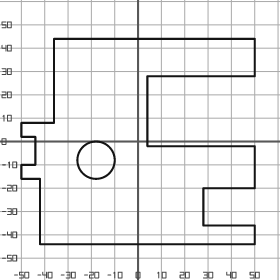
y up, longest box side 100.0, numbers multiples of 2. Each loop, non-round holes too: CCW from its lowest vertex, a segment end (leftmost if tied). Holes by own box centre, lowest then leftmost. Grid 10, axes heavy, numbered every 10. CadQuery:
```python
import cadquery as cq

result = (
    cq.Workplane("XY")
    .moveTo(-42.0, -44.0)
    .lineTo(50.0, -44.0)
    .lineTo(50.0, -36.0)
    .lineTo(28.0, -36.0)
    .lineTo(28.0, -20.0)
    .lineTo(50.0, -20.0)
    .lineTo(50.0, -2.0)
    .lineTo(4.0, -2.0)
    .lineTo(4.0, 28.0)
    .lineTo(50.0, 28.0)
    .lineTo(50.0, 44.0)
    .lineTo(-36.0, 44.0)
    .lineTo(-36.0, 8.0)
    .lineTo(-50.0, 8.0)
    .lineTo(-50.0, 2.0)
    .lineTo(-44.0, 2.0)
    .lineTo(-44.0, -10.0)
    .lineTo(-50.0, -10.0)
    .lineTo(-50.0, -16.0)
    .lineTo(-42.0, -16.0)
    .close()
    .moveTo(-18.0, -8.0)
    .circle(8.0)
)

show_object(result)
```